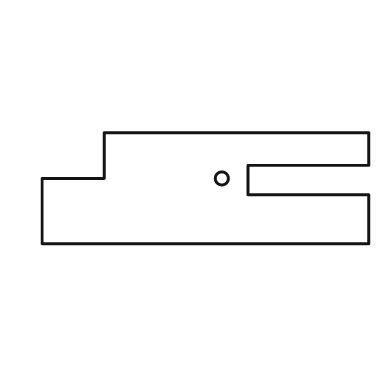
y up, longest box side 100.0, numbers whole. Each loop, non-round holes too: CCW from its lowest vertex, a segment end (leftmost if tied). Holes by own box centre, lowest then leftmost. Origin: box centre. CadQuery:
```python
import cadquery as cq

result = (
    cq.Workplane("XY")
    .moveTo(-50.0, -17.0)
    .lineTo(50.0, -17.0)
    .lineTo(50.0, -2.0)
    .lineTo(13.0, -2.0)
    .lineTo(13.0, 7.0)
    .lineTo(50.0, 7.0)
    .lineTo(50.0, 17.0)
    .lineTo(-31.0, 17.0)
    .lineTo(-31.0, 3.0)
    .lineTo(-50.0, 3.0)
    .close()
    .moveTo(5.0, 3.0)
    .circle(2.0)
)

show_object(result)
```